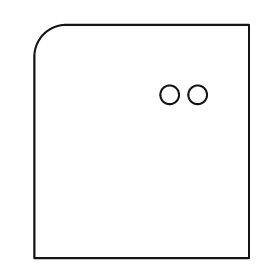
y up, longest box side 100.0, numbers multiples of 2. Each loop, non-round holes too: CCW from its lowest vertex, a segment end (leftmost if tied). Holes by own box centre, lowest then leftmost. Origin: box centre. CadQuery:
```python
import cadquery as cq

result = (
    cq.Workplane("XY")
    .moveTo(-46.0, -50.0)
    .lineTo(46.0, -50.0)
    .lineTo(46.0, 50.0)
    .lineTo(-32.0, 50.0)
    .threePointArc((-42.0, 46.0), (-46.0, 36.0))
    .close()
    .moveTo(12.0, 20.0)
    .circle(4.0)
    .moveTo(24.0, 20.0)
    .circle(4.0)
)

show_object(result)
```